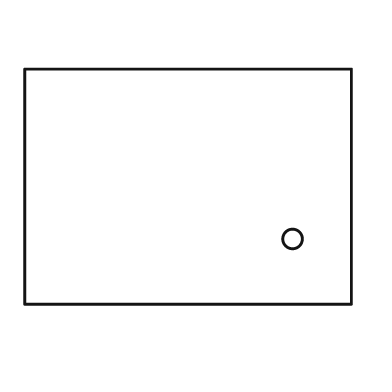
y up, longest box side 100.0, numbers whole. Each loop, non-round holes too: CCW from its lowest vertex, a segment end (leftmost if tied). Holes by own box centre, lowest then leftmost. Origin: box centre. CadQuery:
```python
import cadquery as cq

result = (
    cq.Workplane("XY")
    .moveTo(-50.0, -36.0)
    .lineTo(50.0, -36.0)
    .lineTo(50.0, 36.0)
    .lineTo(-50.0, 36.0)
    .close()
    .moveTo(32.0, -16.0)
    .circle(3.0)
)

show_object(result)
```